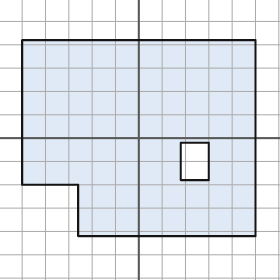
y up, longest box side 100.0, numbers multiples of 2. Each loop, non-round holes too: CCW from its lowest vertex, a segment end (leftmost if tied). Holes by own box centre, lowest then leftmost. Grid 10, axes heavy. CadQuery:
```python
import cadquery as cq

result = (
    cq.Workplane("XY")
    .moveTo(-26.0, -42.0)
    .lineTo(50.0, -42.0)
    .lineTo(50.0, 42.0)
    .lineTo(-50.0, 42.0)
    .lineTo(-50.0, -20.0)
    .lineTo(-26.0, -20.0)
    .close()
    .moveTo(18.0, -18.0)
    .lineTo(30.0, -18.0)
    .lineTo(30.0, -2.0)
    .lineTo(18.0, -2.0)
    .close()
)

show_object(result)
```